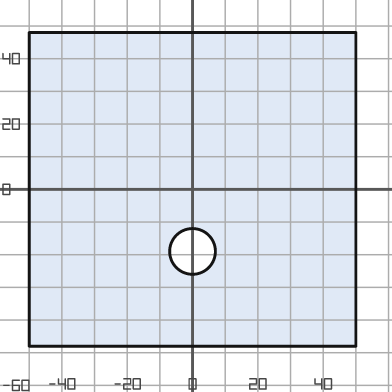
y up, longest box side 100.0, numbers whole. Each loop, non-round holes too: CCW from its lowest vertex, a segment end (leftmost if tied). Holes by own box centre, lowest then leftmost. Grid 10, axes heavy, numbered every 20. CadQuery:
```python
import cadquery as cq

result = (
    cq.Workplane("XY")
    .moveTo(-50.0, -48.0)
    .lineTo(50.0, -48.0)
    .lineTo(50.0, 48.0)
    .lineTo(-50.0, 48.0)
    .close()
    .moveTo(0.0, -19.0)
    .circle(7.0)
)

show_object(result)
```